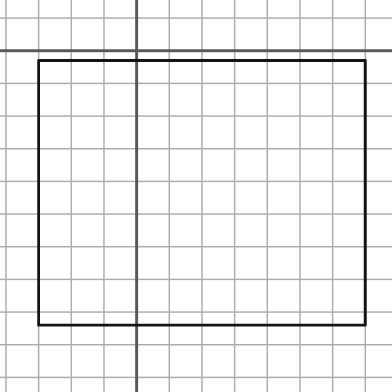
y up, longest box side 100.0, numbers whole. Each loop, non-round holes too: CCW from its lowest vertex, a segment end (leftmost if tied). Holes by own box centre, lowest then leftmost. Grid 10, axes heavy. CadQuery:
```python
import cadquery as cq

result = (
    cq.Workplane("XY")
    .moveTo(-30.0, -84.0)
    .lineTo(70.0, -84.0)
    .lineTo(70.0, -3.0)
    .lineTo(-30.0, -3.0)
    .close()
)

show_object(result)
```